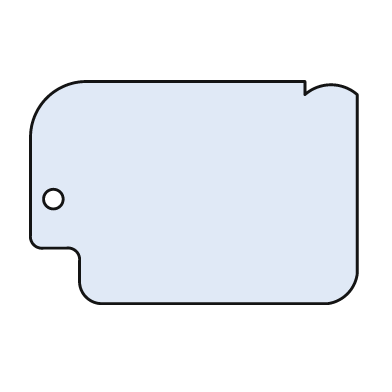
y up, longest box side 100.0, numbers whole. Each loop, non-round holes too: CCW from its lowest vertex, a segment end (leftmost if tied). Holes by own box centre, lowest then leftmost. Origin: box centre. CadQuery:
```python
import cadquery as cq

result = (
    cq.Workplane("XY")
    .moveTo(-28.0, -34.0)
    .lineTo(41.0, -34.0)
    .threePointArc((47.0, -31.0), (50.0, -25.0))
    .lineTo(50.0, 30.0)
    .threePointArc((42.0, 33.0), (34.0, 30.0))
    .lineTo(34.0, 34.0)
    .lineTo(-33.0, 34.0)
    .threePointArc((-45.0, 29.0), (-50.0, 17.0))
    .lineTo(-50.0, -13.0)
    .threePointArc((-49.0, -16.0), (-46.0, -17.0))
    .lineTo(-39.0, -17.0)
    .threePointArc((-36.0, -18.0), (-35.0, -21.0))
    .lineTo(-35.0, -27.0)
    .threePointArc((-33.0, -32.0), (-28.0, -34.0))
    .close()
    .moveTo(-43.0, -2.0)
    .circle(3.0)
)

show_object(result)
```